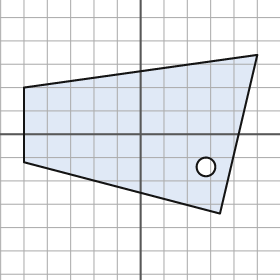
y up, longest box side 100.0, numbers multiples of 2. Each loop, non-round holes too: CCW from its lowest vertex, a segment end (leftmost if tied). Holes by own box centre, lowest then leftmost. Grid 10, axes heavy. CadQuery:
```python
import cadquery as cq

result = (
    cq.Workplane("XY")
    .moveTo(34.0, -34.0)
    .lineTo(50.0, 34.0)
    .lineTo(-50.0, 20.0)
    .lineTo(-50.0, -12.0)
    .close()
    .moveTo(28.0, -14.0)
    .circle(4.0)
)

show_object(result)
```